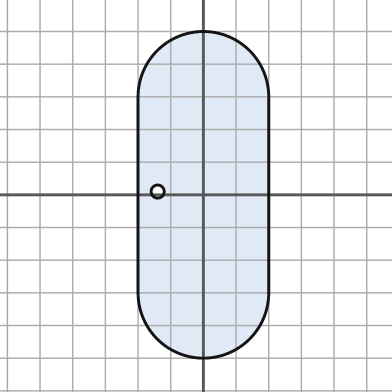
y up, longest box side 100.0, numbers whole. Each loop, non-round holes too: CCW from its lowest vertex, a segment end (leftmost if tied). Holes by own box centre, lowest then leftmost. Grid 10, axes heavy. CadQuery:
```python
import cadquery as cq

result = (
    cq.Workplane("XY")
    .moveTo(-20.0, -30.0)
    .threePointArc((0.0, -50.0), (20.0, -30.0))
    .lineTo(20.0, 30.0)
    .threePointArc((0.0, 50.0), (-20.0, 30.0))
    .close()
    .moveTo(-14.0, 1.0)
    .circle(2.0)
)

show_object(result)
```